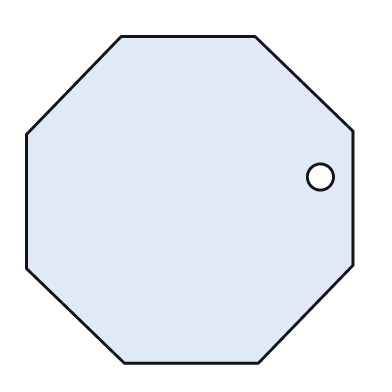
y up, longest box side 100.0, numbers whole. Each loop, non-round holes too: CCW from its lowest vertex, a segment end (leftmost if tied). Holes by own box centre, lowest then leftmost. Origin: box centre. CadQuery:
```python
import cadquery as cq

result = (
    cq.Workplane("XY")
    .moveTo(-20.0, -50.0)
    .lineTo(21.0, -50.0)
    .lineTo(50.0, -20.0)
    .lineTo(50.0, 21.0)
    .lineTo(20.0, 50.0)
    .lineTo(-21.0, 50.0)
    .lineTo(-50.0, 20.0)
    .lineTo(-50.0, -21.0)
    .close()
    .moveTo(40.0, 7.0)
    .circle(4.0)
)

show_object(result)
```